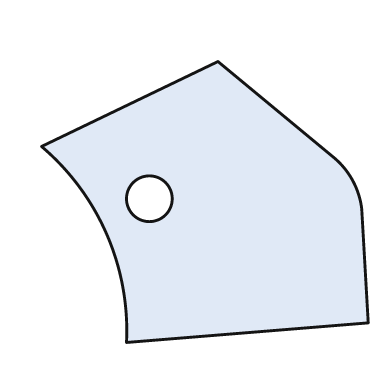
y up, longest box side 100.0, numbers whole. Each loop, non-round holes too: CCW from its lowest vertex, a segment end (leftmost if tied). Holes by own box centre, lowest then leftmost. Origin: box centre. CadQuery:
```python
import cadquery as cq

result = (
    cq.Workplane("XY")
    .moveTo(-24.0, -43.0)
    .lineTo(50.0, -37.0)
    .lineTo(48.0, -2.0)
    .threePointArc((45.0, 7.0), (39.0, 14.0))
    .lineTo(4.0, 43.0)
    .lineTo(-50.0, 17.0)
    .threePointArc((-30.0, -10.0), (-24.0, -43.0))
    .close()
    .moveTo(-17.0, 1.0)
    .circle(7.0)
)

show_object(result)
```